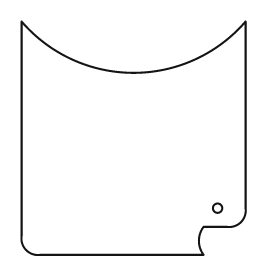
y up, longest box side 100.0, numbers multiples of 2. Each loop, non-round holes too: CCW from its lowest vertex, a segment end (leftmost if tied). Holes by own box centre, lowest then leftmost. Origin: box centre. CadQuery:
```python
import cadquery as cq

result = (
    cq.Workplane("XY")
    .moveTo(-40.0, -50.0)
    .lineTo(30.0, -50.0)
    .threePointArc((28.0, -44.0), (30.0, -38.0))
    .lineTo(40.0, -38.0)
    .threePointArc((46.0, -36.0), (48.0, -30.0))
    .lineTo(48.0, 50.0)
    .threePointArc((0.0, 28.0), (-48.0, 50.0))
    .lineTo(-48.0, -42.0)
    .threePointArc((-46.0, -48.0), (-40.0, -50.0))
    .close()
    .moveTo(36.0, -30.0)
    .circle(2.0)
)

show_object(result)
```